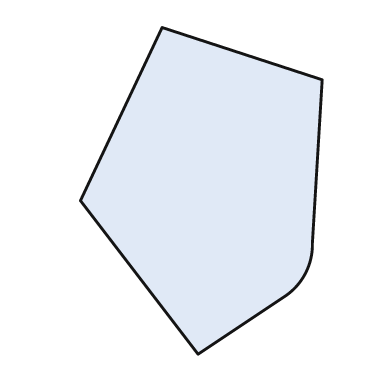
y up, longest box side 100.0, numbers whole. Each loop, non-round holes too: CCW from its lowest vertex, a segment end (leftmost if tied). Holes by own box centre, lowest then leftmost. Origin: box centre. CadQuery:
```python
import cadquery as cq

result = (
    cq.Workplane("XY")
    .moveTo(-1.0, -50.0)
    .lineTo(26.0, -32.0)
    .threePointArc((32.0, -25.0), (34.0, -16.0))
    .lineTo(37.0, 34.0)
    .lineTo(-12.0, 50.0)
    .lineTo(-37.0, -3.0)
    .close()
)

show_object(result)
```